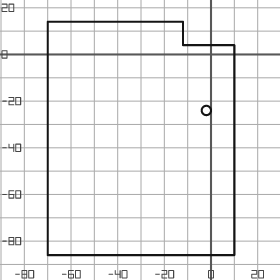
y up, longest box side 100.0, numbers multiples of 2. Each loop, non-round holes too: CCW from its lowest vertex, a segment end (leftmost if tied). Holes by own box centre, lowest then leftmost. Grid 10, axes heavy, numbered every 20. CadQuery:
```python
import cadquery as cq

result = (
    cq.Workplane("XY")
    .moveTo(-70.0, -86.0)
    .lineTo(10.0, -86.0)
    .lineTo(10.0, 4.0)
    .lineTo(-12.0, 4.0)
    .lineTo(-12.0, 14.0)
    .lineTo(-70.0, 14.0)
    .close()
    .moveTo(-2.0, -24.0)
    .circle(2.0)
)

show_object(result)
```